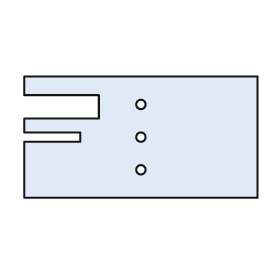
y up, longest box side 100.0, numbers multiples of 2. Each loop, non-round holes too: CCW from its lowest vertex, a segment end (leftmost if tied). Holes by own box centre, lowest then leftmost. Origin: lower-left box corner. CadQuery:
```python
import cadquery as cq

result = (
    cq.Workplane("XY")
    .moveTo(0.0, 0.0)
    .lineTo(100.0, 0.0)
    .lineTo(100.0, 52.0)
    .lineTo(0.0, 52.0)
    .lineTo(0.0, 44.0)
    .lineTo(32.0, 44.0)
    .lineTo(32.0, 34.0)
    .lineTo(0.0, 34.0)
    .lineTo(0.0, 28.0)
    .lineTo(24.0, 28.0)
    .lineTo(24.0, 24.0)
    .lineTo(0.0, 24.0)
    .close()
    .moveTo(50.0, 12.0)
    .circle(2.0)
    .moveTo(50.0, 26.0)
    .circle(2.0)
    .moveTo(50.0, 40.0)
    .circle(2.0)
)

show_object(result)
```